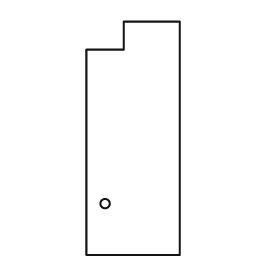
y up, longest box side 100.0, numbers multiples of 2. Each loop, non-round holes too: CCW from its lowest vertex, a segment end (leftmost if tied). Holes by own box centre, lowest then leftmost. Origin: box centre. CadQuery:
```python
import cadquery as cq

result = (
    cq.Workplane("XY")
    .moveTo(-20.0, -50.0)
    .lineTo(20.0, -50.0)
    .lineTo(20.0, 50.0)
    .lineTo(-4.0, 50.0)
    .lineTo(-4.0, 38.0)
    .lineTo(-20.0, 38.0)
    .close()
    .moveTo(-12.0, -28.0)
    .circle(2.0)
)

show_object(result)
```